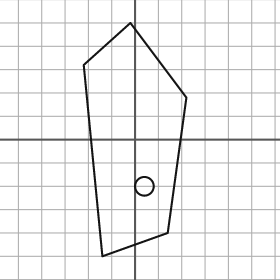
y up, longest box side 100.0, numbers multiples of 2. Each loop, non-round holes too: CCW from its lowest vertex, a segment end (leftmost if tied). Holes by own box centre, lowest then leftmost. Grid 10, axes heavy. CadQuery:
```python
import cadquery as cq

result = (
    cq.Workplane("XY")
    .moveTo(-14.0, -50.0)
    .lineTo(14.0, -40.0)
    .lineTo(22.0, 18.0)
    .lineTo(-2.0, 50.0)
    .lineTo(-22.0, 32.0)
    .close()
    .moveTo(4.0, -20.0)
    .circle(4.0)
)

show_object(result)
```